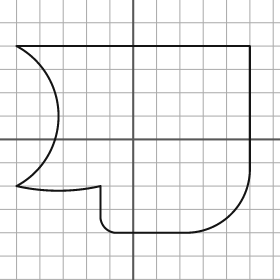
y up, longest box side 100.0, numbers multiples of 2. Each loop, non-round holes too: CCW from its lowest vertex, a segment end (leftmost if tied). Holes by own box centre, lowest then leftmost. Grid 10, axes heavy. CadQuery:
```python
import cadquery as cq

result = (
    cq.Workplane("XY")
    .moveTo(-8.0, -40.0)
    .lineTo(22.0, -40.0)
    .threePointArc((42.0, -32.0), (50.0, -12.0))
    .lineTo(50.0, 40.0)
    .lineTo(-50.0, 40.0)
    .threePointArc((-32.0, 10.0), (-50.0, -20.0))
    .threePointArc((-32.0, -22.0), (-14.0, -20.0))
    .lineTo(-14.0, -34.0)
    .threePointArc((-12.0, -38.0), (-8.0, -40.0))
    .close()
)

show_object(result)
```